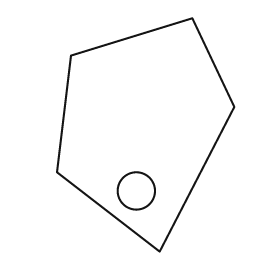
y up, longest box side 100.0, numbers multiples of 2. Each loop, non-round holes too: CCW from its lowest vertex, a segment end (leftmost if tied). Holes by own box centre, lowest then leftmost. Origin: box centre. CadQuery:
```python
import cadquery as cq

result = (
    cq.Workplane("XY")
    .moveTo(6.0, -50.0)
    .lineTo(38.0, 12.0)
    .lineTo(20.0, 50.0)
    .lineTo(-32.0, 34.0)
    .lineTo(-38.0, -16.0)
    .close()
    .moveTo(-4.0, -24.0)
    .circle(8.0)
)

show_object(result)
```